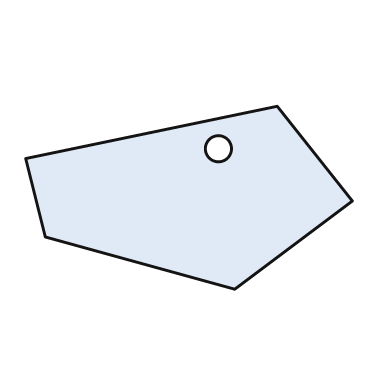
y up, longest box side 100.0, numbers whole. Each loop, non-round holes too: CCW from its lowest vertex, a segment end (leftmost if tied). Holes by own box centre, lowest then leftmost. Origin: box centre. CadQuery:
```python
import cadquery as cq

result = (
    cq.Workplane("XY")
    .moveTo(14.0, -28.0)
    .lineTo(50.0, -1.0)
    .lineTo(27.0, 28.0)
    .lineTo(-50.0, 12.0)
    .lineTo(-44.0, -12.0)
    .close()
    .moveTo(9.0, 15.0)
    .circle(4.0)
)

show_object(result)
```